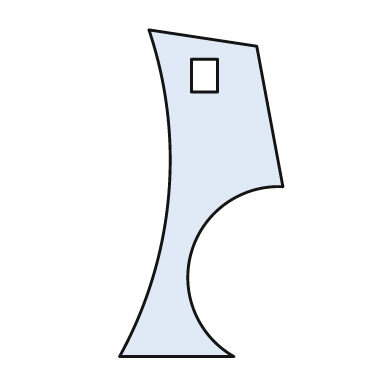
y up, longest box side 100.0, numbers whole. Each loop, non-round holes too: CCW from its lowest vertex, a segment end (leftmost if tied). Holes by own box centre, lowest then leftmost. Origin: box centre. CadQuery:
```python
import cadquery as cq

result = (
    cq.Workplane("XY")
    .moveTo(-25.0, -50.0)
    .lineTo(10.0, -50.0)
    .threePointArc((-3.0, -18.0), (25.0, 2.0))
    .lineTo(17.0, 45.0)
    .lineTo(-16.0, 50.0)
    .threePointArc((-10.0, -1.0), (-25.0, -50.0))
    .close()
    .moveTo(-3.0, 31.0)
    .lineTo(5.0, 31.0)
    .lineTo(5.0, 41.0)
    .lineTo(-3.0, 41.0)
    .close()
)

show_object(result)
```